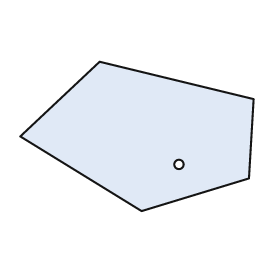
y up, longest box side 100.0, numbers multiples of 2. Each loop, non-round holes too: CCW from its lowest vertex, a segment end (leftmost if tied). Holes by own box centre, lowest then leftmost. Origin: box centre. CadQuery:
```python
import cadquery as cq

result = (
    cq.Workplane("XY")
    .moveTo(2.0, -32.0)
    .lineTo(48.0, -18.0)
    .lineTo(50.0, 16.0)
    .lineTo(-16.0, 32.0)
    .lineTo(-50.0, 0.0)
    .close()
    .moveTo(18.0, -12.0)
    .circle(2.0)
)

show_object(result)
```